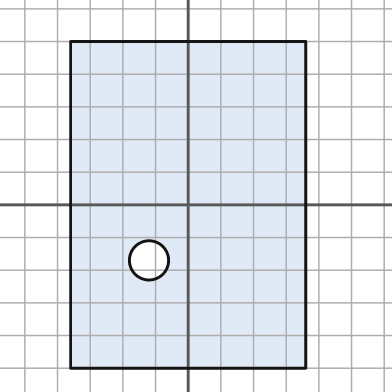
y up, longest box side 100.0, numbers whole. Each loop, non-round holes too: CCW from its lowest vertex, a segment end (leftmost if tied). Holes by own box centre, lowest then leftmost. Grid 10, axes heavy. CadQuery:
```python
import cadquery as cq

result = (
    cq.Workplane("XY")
    .moveTo(-36.0, -50.0)
    .lineTo(36.0, -50.0)
    .lineTo(36.0, 50.0)
    .lineTo(-36.0, 50.0)
    .close()
    .moveTo(-12.0, -17.0)
    .circle(6.0)
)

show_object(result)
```